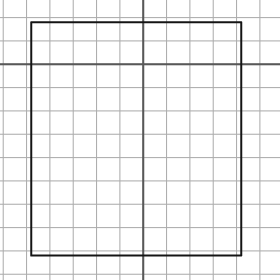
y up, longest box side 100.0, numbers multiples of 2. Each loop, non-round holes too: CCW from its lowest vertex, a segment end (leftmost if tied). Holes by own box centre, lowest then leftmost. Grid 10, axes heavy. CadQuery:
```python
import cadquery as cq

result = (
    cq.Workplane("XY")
    .moveTo(-48.0, -82.0)
    .lineTo(42.0, -82.0)
    .lineTo(42.0, 18.0)
    .lineTo(-48.0, 18.0)
    .close()
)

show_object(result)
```